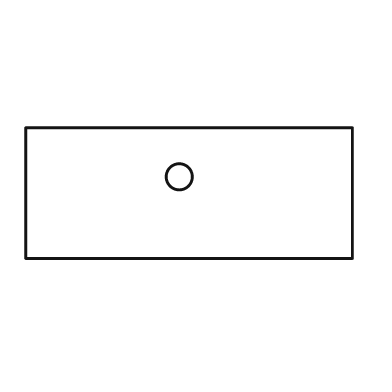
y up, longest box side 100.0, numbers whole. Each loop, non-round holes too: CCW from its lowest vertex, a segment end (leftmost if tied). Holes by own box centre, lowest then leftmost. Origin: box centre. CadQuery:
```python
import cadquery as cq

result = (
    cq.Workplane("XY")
    .moveTo(-50.0, -20.0)
    .lineTo(50.0, -20.0)
    .lineTo(50.0, 20.0)
    .lineTo(-50.0, 20.0)
    .close()
    .moveTo(-3.0, 5.0)
    .circle(4.0)
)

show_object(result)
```